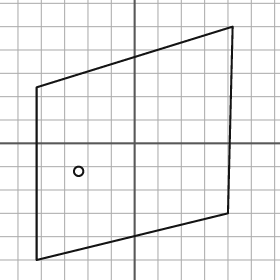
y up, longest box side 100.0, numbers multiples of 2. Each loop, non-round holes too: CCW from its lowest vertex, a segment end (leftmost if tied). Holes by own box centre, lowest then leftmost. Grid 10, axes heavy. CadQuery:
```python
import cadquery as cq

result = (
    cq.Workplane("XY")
    .moveTo(-42.0, -50.0)
    .lineTo(40.0, -30.0)
    .lineTo(42.0, 50.0)
    .lineTo(-42.0, 24.0)
    .close()
    .moveTo(-24.0, -12.0)
    .circle(2.0)
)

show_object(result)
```